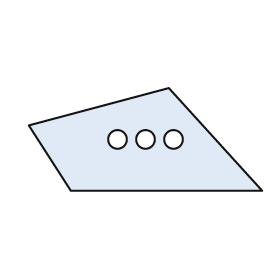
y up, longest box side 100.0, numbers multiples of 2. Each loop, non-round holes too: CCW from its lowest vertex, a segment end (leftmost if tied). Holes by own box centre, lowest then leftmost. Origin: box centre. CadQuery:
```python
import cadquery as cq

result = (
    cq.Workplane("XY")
    .moveTo(-32.0, -22.0)
    .lineTo(50.0, -22.0)
    .lineTo(10.0, 22.0)
    .lineTo(-50.0, 6.0)
    .close()
    .moveTo(-12.0, 0.0)
    .circle(4.0)
    .moveTo(0.0, 0.0)
    .circle(4.0)
    .moveTo(12.0, 0.0)
    .circle(4.0)
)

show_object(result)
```